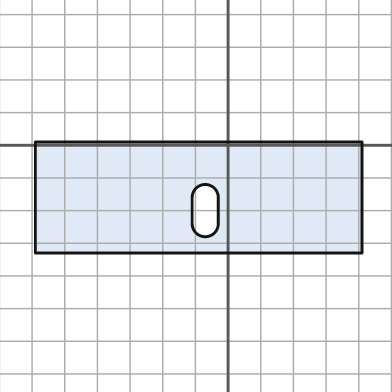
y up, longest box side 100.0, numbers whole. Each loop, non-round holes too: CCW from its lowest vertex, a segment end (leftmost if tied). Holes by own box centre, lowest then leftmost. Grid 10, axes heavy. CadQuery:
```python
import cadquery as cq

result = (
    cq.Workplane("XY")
    .moveTo(-59.0, -33.0)
    .lineTo(41.0, -33.0)
    .lineTo(41.0, 1.0)
    .lineTo(-59.0, 1.0)
    .close()
    .moveTo(-11.0, -24.0)
    .threePointArc((-7.0, -28.0), (-3.0, -24.0))
    .lineTo(-3.0, -16.0)
    .threePointArc((-7.0, -12.0), (-11.0, -16.0))
    .close()
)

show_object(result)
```